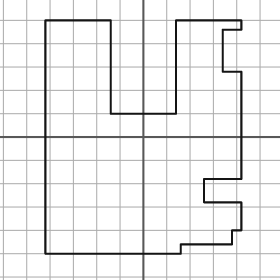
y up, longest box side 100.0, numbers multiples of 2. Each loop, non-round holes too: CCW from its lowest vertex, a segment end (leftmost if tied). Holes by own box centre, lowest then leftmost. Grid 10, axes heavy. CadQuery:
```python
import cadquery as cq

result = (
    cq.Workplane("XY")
    .moveTo(-42.0, -50.0)
    .lineTo(16.0, -50.0)
    .lineTo(16.0, -46.0)
    .lineTo(38.0, -46.0)
    .lineTo(38.0, -40.0)
    .lineTo(42.0, -40.0)
    .lineTo(42.0, -28.0)
    .lineTo(26.0, -28.0)
    .lineTo(26.0, -18.0)
    .lineTo(42.0, -18.0)
    .lineTo(42.0, 28.0)
    .lineTo(34.0, 28.0)
    .lineTo(34.0, 46.0)
    .lineTo(42.0, 46.0)
    .lineTo(42.0, 50.0)
    .lineTo(14.0, 50.0)
    .lineTo(14.0, 10.0)
    .lineTo(-14.0, 10.0)
    .lineTo(-14.0, 50.0)
    .lineTo(-42.0, 50.0)
    .close()
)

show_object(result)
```